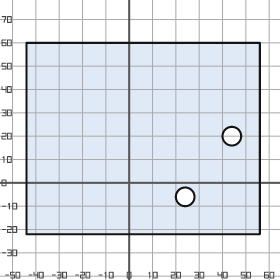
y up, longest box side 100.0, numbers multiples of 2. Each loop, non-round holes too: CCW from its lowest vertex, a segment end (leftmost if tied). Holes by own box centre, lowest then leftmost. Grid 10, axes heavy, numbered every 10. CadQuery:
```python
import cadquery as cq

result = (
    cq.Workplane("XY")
    .moveTo(-44.0, -22.0)
    .lineTo(56.0, -22.0)
    .lineTo(56.0, 60.0)
    .lineTo(-44.0, 60.0)
    .close()
    .moveTo(24.0, -6.0)
    .circle(4.0)
    .moveTo(44.0, 20.0)
    .circle(4.0)
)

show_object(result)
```